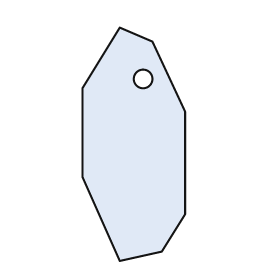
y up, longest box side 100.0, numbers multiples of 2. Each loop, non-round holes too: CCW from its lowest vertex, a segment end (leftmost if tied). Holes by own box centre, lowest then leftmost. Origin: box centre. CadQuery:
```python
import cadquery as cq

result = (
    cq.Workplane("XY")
    .moveTo(-6.0, -50.0)
    .lineTo(12.0, -46.0)
    .lineTo(22.0, -30.0)
    .lineTo(22.0, 14.0)
    .lineTo(8.0, 44.0)
    .lineTo(-6.0, 50.0)
    .lineTo(-22.0, 24.0)
    .lineTo(-22.0, -14.0)
    .close()
    .moveTo(4.0, 28.0)
    .circle(4.0)
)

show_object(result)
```